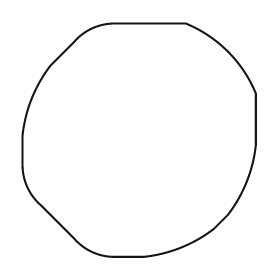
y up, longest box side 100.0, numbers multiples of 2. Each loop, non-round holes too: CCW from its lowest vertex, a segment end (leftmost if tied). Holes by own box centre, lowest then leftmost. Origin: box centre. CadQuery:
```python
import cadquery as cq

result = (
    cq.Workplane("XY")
    .moveTo(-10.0, -50.0)
    .lineTo(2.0, -50.0)
    .threePointArc((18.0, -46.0), (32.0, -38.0))
    .lineTo(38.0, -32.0)
    .threePointArc((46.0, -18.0), (50.0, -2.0))
    .lineTo(50.0, 20.0)
    .threePointArc((38.0, 38.0), (20.0, 50.0))
    .lineTo(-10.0, 50.0)
    .threePointArc((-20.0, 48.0), (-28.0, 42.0))
    .lineTo(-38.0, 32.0)
    .threePointArc((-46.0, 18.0), (-50.0, 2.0))
    .lineTo(-50.0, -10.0)
    .threePointArc((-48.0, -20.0), (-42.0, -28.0))
    .lineTo(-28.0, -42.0)
    .threePointArc((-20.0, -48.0), (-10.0, -50.0))
    .close()
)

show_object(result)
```